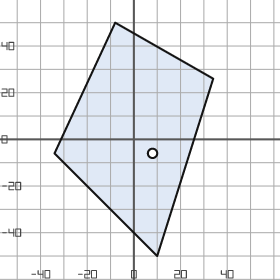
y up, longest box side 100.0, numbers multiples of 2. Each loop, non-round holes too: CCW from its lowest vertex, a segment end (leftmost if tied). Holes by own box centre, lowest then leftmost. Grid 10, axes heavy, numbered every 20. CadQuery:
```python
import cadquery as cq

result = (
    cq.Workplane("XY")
    .moveTo(10.0, -50.0)
    .lineTo(34.0, 26.0)
    .lineTo(-8.0, 50.0)
    .lineTo(-34.0, -6.0)
    .close()
    .moveTo(8.0, -6.0)
    .circle(2.0)
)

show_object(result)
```